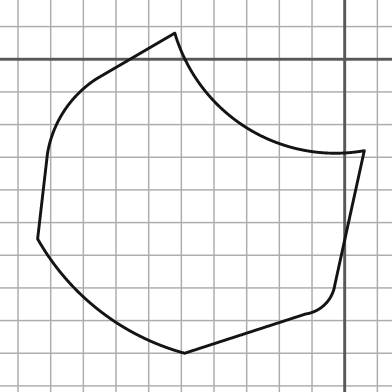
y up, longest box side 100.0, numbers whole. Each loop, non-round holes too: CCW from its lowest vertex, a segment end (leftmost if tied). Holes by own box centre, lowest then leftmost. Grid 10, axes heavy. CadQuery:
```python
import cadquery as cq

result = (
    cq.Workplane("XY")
    .moveTo(-49.0, -90.0)
    .lineTo(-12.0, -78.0)
    .threePointArc((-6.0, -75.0), (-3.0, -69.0))
    .lineTo(6.0, -28.0)
    .threePointArc((-30.0, -21.0), (-52.0, 8.0))
    .lineTo(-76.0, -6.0)
    .threePointArc((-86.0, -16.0), (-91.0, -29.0))
    .lineTo(-94.0, -55.0)
    .threePointArc((-75.0, -77.0), (-49.0, -90.0))
    .close()
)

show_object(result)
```